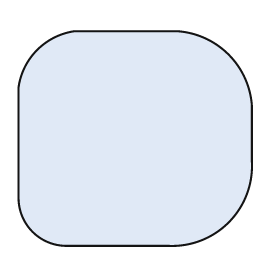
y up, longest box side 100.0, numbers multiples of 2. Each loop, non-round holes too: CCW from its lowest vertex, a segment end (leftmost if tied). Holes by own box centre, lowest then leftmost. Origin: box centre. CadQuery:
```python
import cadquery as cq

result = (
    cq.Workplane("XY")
    .moveTo(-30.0, -46.0)
    .lineTo(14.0, -46.0)
    .threePointArc((40.0, -36.0), (50.0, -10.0))
    .lineTo(50.0, 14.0)
    .threePointArc((40.0, 36.0), (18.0, 46.0))
    .lineTo(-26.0, 46.0)
    .threePointArc((-42.0, 38.0), (-50.0, 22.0))
    .lineTo(-50.0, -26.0)
    .threePointArc((-44.0, -40.0), (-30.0, -46.0))
    .close()
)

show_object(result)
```